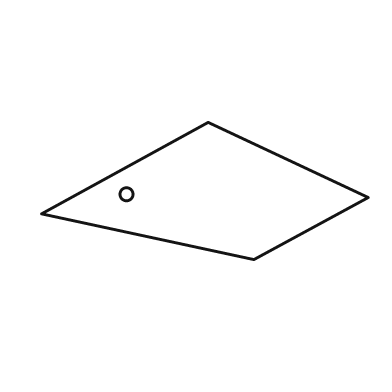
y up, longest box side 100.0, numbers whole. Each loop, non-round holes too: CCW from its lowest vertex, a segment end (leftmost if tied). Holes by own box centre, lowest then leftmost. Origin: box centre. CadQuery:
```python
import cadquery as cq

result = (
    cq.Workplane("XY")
    .moveTo(15.0, -21.0)
    .lineTo(50.0, -2.0)
    .lineTo(1.0, 21.0)
    .lineTo(-50.0, -7.0)
    .close()
    .moveTo(-24.0, -1.0)
    .circle(2.0)
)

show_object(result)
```